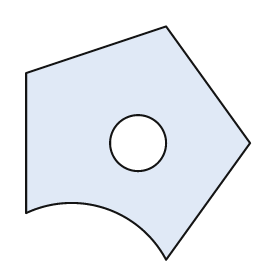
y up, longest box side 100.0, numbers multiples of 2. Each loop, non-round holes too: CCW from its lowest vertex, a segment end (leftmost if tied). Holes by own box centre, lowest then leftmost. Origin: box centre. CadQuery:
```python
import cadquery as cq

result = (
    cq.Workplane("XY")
    .moveTo(12.0, -50.0)
    .lineTo(48.0, 0.0)
    .lineTo(12.0, 50.0)
    .lineTo(-48.0, 30.0)
    .lineTo(-48.0, -30.0)
    .threePointArc((-14.0, -28.0), (12.0, -50.0))
    .close()
    .moveTo(0.0, 0.0)
    .circle(12.0)
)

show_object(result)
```